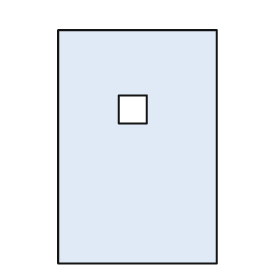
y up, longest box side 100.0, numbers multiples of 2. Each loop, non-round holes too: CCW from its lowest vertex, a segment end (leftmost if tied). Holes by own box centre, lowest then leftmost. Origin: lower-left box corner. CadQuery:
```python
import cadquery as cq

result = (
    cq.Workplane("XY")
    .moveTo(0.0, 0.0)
    .lineTo(68.0, 0.0)
    .lineTo(68.0, 100.0)
    .lineTo(0.0, 100.0)
    .close()
    .moveTo(26.0, 60.0)
    .lineTo(38.0, 60.0)
    .lineTo(38.0, 72.0)
    .lineTo(26.0, 72.0)
    .close()
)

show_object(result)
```